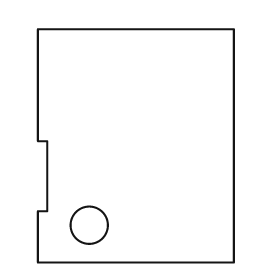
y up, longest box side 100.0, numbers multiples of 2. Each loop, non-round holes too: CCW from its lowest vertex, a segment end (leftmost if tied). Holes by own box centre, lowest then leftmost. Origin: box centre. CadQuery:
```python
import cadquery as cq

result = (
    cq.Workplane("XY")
    .moveTo(-42.0, -50.0)
    .lineTo(42.0, -50.0)
    .lineTo(42.0, 50.0)
    .lineTo(-42.0, 50.0)
    .lineTo(-42.0, 2.0)
    .lineTo(-38.0, 2.0)
    .lineTo(-38.0, -28.0)
    .lineTo(-42.0, -28.0)
    .close()
    .moveTo(-20.0, -34.0)
    .circle(8.0)
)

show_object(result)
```